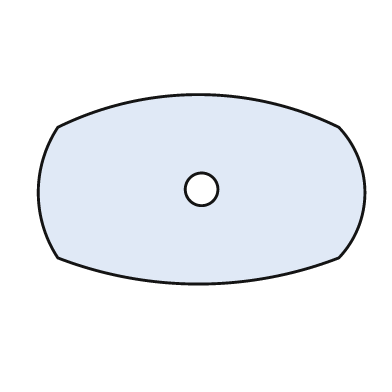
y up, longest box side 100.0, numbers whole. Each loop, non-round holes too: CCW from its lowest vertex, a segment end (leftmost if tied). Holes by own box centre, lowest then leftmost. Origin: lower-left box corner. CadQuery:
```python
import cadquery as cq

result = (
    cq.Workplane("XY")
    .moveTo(6.0, 8.0)
    .threePointArc((49.0, 0.0), (92.0, 8.0))
    .threePointArc((100.0, 28.0), (92.0, 48.0))
    .threePointArc((49.0, 58.0), (6.0, 48.0))
    .threePointArc((0.0, 28.0), (6.0, 8.0))
    .close()
    .moveTo(50.0, 29.0)
    .circle(5.0)
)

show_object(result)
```